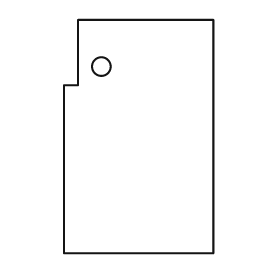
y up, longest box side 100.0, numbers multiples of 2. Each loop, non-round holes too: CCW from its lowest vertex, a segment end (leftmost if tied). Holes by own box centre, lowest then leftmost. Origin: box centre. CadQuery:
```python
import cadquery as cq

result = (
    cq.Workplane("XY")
    .moveTo(-32.0, -50.0)
    .lineTo(32.0, -50.0)
    .lineTo(32.0, 50.0)
    .lineTo(-26.0, 50.0)
    .lineTo(-26.0, 22.0)
    .lineTo(-32.0, 22.0)
    .close()
    .moveTo(-16.0, 30.0)
    .circle(4.0)
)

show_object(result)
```